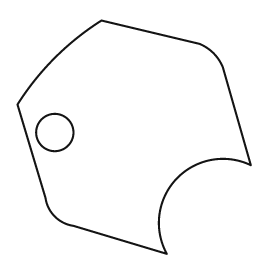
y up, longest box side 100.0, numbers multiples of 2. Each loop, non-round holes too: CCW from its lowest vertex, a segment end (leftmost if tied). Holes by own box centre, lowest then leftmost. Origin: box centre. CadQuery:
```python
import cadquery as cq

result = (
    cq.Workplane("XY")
    .moveTo(14.0, -50.0)
    .threePointArc((18.0, -18.0), (50.0, -12.0))
    .lineTo(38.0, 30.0)
    .threePointArc((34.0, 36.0), (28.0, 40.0))
    .lineTo(-14.0, 50.0)
    .threePointArc((-34.0, 34.0), (-50.0, 14.0))
    .lineTo(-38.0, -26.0)
    .threePointArc((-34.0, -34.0), (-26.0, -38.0))
    .close()
    .moveTo(-34.0, 2.0)
    .circle(8.0)
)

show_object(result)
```